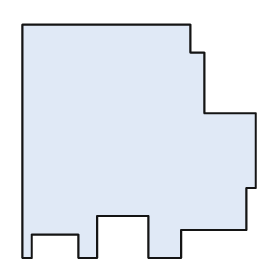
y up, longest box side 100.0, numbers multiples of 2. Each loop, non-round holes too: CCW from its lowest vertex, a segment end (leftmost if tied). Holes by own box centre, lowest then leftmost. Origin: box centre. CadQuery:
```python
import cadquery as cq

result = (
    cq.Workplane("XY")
    .moveTo(-50.0, -50.0)
    .lineTo(-46.0, -50.0)
    .lineTo(-46.0, -40.0)
    .lineTo(-26.0, -40.0)
    .lineTo(-26.0, -50.0)
    .lineTo(-18.0, -50.0)
    .lineTo(-18.0, -32.0)
    .lineTo(4.0, -32.0)
    .lineTo(4.0, -50.0)
    .lineTo(18.0, -50.0)
    .lineTo(18.0, -38.0)
    .lineTo(46.0, -38.0)
    .lineTo(46.0, -20.0)
    .lineTo(50.0, -20.0)
    .lineTo(50.0, 12.0)
    .lineTo(28.0, 12.0)
    .lineTo(28.0, 38.0)
    .lineTo(22.0, 38.0)
    .lineTo(22.0, 50.0)
    .lineTo(-50.0, 50.0)
    .close()
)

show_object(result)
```